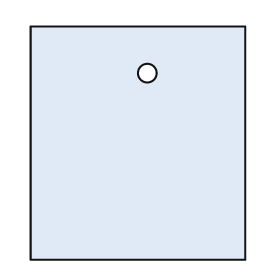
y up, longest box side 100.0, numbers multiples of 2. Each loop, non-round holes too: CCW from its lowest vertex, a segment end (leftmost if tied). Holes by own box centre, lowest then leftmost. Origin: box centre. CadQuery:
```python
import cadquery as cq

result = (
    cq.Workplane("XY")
    .moveTo(-46.0, -50.0)
    .lineTo(46.0, -50.0)
    .lineTo(46.0, 50.0)
    .lineTo(-46.0, 50.0)
    .close()
    .moveTo(4.0, 30.0)
    .circle(4.0)
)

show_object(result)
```